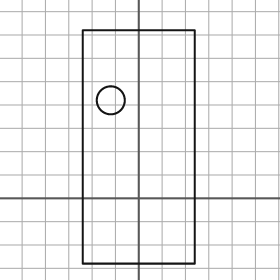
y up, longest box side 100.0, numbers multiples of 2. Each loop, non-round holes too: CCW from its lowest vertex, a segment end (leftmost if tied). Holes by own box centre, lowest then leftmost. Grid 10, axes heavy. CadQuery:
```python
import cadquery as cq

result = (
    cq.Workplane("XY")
    .moveTo(-24.0, -28.0)
    .lineTo(24.0, -28.0)
    .lineTo(24.0, 72.0)
    .lineTo(-24.0, 72.0)
    .close()
    .moveTo(-12.0, 42.0)
    .circle(6.0)
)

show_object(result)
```